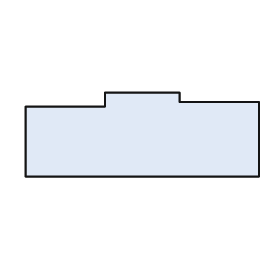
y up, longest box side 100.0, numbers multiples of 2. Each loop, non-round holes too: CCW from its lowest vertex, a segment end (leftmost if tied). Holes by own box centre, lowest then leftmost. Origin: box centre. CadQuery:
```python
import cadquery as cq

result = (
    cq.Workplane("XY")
    .moveTo(-50.0, -18.0)
    .lineTo(50.0, -18.0)
    .lineTo(50.0, 14.0)
    .lineTo(16.0, 14.0)
    .lineTo(16.0, 18.0)
    .lineTo(-16.0, 18.0)
    .lineTo(-16.0, 12.0)
    .lineTo(-50.0, 12.0)
    .close()
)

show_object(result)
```